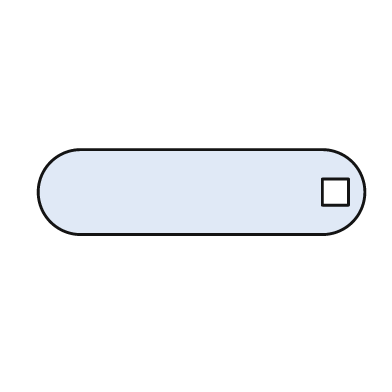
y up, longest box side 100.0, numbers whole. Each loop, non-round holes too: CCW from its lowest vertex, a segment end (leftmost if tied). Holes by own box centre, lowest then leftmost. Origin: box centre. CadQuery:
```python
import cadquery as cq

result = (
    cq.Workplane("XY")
    .moveTo(-37.0, -13.0)
    .lineTo(37.0, -13.0)
    .threePointArc((50.0, 0.0), (37.0, 13.0))
    .lineTo(-37.0, 13.0)
    .threePointArc((-50.0, 0.0), (-37.0, -13.0))
    .close()
    .moveTo(37.0, -4.0)
    .lineTo(45.0, -4.0)
    .lineTo(45.0, 4.0)
    .lineTo(37.0, 4.0)
    .close()
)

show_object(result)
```